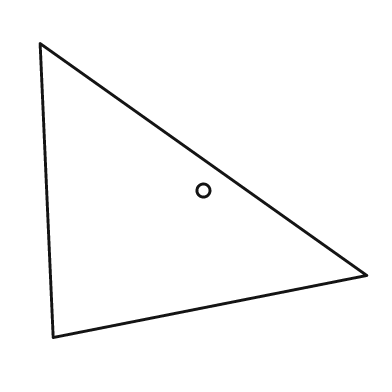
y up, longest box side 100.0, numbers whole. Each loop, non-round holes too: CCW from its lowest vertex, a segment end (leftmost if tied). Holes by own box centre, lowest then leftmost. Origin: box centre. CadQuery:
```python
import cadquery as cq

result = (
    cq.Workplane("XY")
    .moveTo(-46.0, -45.0)
    .lineTo(50.0, -26.0)
    .lineTo(-50.0, 45.0)
    .close()
    .moveTo(0.0, 0.0)
    .circle(2.0)
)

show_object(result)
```